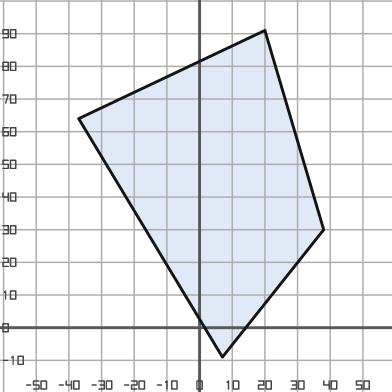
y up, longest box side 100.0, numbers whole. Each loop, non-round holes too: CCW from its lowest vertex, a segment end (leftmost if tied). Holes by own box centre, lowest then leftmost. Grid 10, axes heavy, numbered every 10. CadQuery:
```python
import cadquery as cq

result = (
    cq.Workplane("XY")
    .moveTo(7.0, -9.0)
    .lineTo(38.0, 30.0)
    .lineTo(20.0, 91.0)
    .lineTo(-37.0, 64.0)
    .close()
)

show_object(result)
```